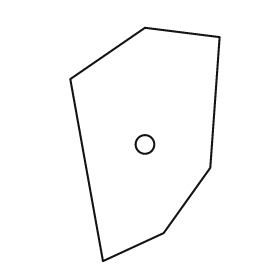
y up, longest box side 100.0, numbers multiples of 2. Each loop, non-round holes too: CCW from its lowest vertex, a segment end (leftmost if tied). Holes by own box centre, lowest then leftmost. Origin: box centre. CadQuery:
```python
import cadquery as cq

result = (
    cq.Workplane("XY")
    .moveTo(-18.0, -50.0)
    .lineTo(8.0, -38.0)
    .lineTo(28.0, -10.0)
    .lineTo(32.0, 46.0)
    .lineTo(0.0, 50.0)
    .lineTo(-32.0, 28.0)
    .close()
    .moveTo(0.0, 0.0)
    .circle(4.0)
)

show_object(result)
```